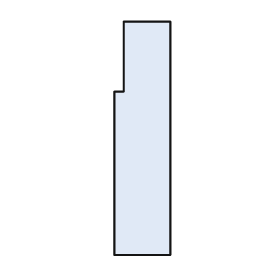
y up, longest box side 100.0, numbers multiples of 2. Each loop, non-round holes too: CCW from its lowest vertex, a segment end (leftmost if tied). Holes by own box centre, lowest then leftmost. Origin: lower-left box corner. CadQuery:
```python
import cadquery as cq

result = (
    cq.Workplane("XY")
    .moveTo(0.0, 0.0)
    .lineTo(24.0, 0.0)
    .lineTo(24.0, 100.0)
    .lineTo(4.0, 100.0)
    .lineTo(4.0, 70.0)
    .lineTo(0.0, 70.0)
    .close()
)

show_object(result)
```